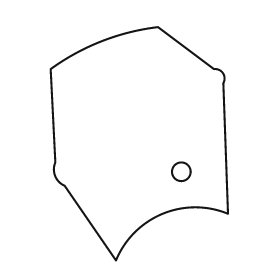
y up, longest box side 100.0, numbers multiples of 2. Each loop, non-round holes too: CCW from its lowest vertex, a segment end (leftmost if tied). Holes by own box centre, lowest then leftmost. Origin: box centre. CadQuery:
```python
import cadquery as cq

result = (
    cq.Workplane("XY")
    .moveTo(-10.0, -50.0)
    .threePointArc((10.0, -30.0), (38.0, -30.0))
    .lineTo(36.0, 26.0)
    .threePointArc((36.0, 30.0), (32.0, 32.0))
    .lineTo(8.0, 50.0)
    .threePointArc((-16.0, 44.0), (-38.0, 32.0))
    .lineTo(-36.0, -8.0)
    .threePointArc((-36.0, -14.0), (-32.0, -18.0))
    .close()
    .moveTo(18.0, -12.0)
    .circle(4.0)
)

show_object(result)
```